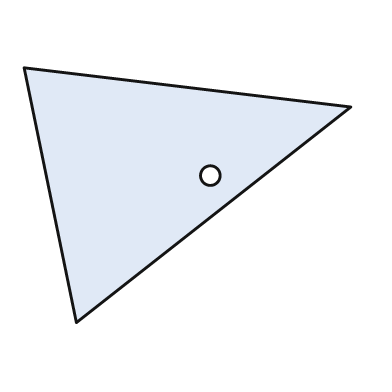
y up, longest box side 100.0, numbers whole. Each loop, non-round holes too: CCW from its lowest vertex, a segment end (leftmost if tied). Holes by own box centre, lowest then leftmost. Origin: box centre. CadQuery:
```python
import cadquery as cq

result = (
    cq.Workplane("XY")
    .moveTo(-34.0, -39.0)
    .lineTo(50.0, 27.0)
    .lineTo(-50.0, 39.0)
    .close()
    .moveTo(7.0, 6.0)
    .circle(3.0)
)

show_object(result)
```